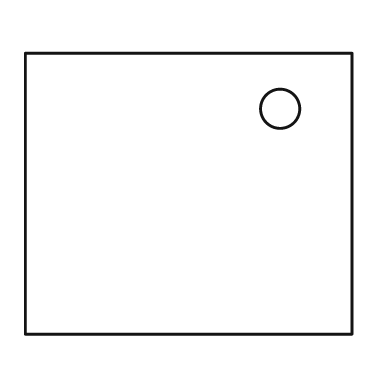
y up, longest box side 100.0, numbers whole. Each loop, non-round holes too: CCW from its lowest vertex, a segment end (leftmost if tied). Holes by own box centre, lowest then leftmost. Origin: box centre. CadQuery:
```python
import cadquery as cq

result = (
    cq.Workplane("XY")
    .moveTo(-50.0, -43.0)
    .lineTo(50.0, -43.0)
    .lineTo(50.0, 43.0)
    .lineTo(-50.0, 43.0)
    .close()
    .moveTo(28.0, 26.0)
    .circle(6.0)
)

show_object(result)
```